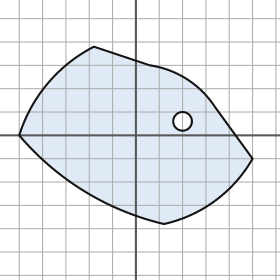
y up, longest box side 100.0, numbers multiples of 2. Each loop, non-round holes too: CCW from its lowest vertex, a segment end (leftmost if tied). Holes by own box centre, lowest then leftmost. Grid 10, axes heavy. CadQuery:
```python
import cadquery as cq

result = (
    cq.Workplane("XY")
    .moveTo(12.0, -38.0)
    .threePointArc((34.0, -28.0), (50.0, -10.0))
    .lineTo(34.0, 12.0)
    .threePointArc((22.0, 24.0), (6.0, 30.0))
    .lineTo(-18.0, 38.0)
    .threePointArc((-38.0, 22.0), (-50.0, 0.0))
    .threePointArc((-22.0, -24.0), (12.0, -38.0))
    .close()
    .moveTo(20.0, 6.0)
    .circle(4.0)
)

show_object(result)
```